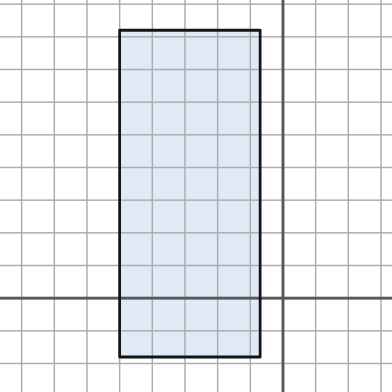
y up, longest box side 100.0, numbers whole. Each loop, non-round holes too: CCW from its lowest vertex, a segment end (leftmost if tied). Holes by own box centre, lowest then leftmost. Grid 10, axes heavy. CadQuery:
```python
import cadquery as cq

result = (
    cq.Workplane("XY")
    .moveTo(-50.0, -18.0)
    .lineTo(-7.0, -18.0)
    .lineTo(-7.0, 82.0)
    .lineTo(-50.0, 82.0)
    .close()
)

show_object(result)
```